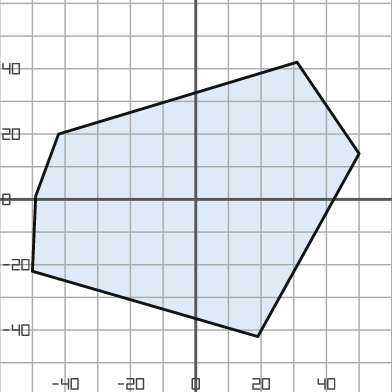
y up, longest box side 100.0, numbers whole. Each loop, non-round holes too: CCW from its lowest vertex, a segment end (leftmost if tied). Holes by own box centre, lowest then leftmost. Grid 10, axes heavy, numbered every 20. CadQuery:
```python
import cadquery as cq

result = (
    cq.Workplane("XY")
    .moveTo(19.0, -42.0)
    .lineTo(50.0, 14.0)
    .lineTo(31.0, 42.0)
    .lineTo(-42.0, 20.0)
    .lineTo(-49.0, 1.0)
    .lineTo(-50.0, -22.0)
    .close()
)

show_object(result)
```